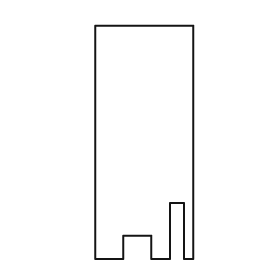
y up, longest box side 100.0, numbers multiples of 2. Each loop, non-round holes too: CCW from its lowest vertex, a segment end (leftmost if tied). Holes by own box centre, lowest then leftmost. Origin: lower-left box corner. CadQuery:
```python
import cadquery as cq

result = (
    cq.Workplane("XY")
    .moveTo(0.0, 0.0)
    .lineTo(12.0, 0.0)
    .lineTo(12.0, 10.0)
    .lineTo(24.0, 10.0)
    .lineTo(24.0, 0.0)
    .lineTo(32.0, 0.0)
    .lineTo(32.0, 24.0)
    .lineTo(38.0, 24.0)
    .lineTo(38.0, 0.0)
    .lineTo(42.0, 0.0)
    .lineTo(42.0, 100.0)
    .lineTo(0.0, 100.0)
    .close()
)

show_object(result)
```